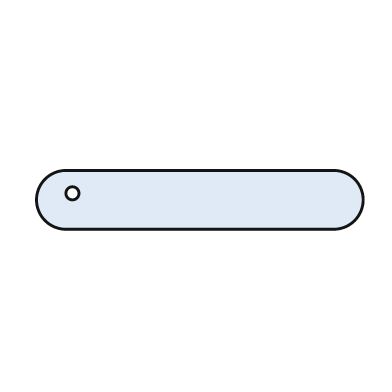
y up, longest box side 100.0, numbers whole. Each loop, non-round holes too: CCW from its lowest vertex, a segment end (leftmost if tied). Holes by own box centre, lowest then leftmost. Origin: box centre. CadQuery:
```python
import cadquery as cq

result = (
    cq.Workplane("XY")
    .moveTo(-41.0, -9.0)
    .lineTo(41.0, -9.0)
    .threePointArc((50.0, 0.0), (41.0, 9.0))
    .lineTo(-41.0, 9.0)
    .threePointArc((-50.0, 0.0), (-41.0, -9.0))
    .close()
    .moveTo(-39.0, 2.0)
    .circle(2.0)
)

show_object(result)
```